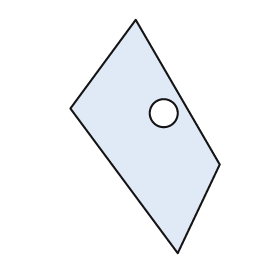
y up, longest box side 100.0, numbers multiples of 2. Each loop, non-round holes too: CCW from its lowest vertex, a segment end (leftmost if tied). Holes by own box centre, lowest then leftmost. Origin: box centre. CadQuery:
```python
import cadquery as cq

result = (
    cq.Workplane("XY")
    .moveTo(14.0, -50.0)
    .lineTo(32.0, -12.0)
    .lineTo(-4.0, 50.0)
    .lineTo(-32.0, 12.0)
    .close()
    .moveTo(8.0, 10.0)
    .circle(6.0)
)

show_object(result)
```